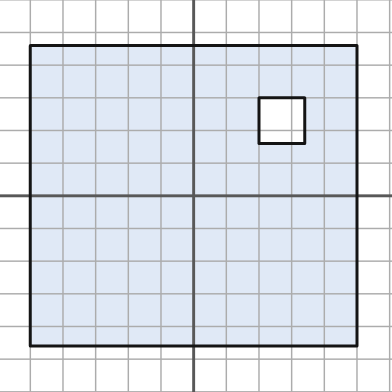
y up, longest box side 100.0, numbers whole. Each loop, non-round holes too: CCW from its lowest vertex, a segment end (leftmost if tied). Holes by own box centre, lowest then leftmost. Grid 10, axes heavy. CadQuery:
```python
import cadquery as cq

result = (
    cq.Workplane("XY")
    .moveTo(-50.0, -46.0)
    .lineTo(50.0, -46.0)
    .lineTo(50.0, 46.0)
    .lineTo(-50.0, 46.0)
    .close()
    .moveTo(20.0, 16.0)
    .lineTo(34.0, 16.0)
    .lineTo(34.0, 30.0)
    .lineTo(20.0, 30.0)
    .close()
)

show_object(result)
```